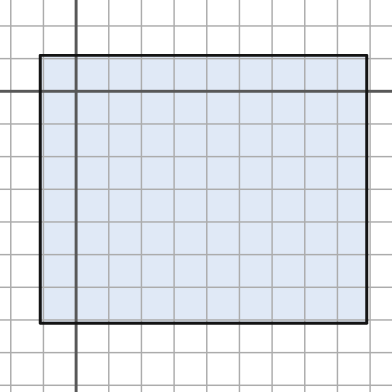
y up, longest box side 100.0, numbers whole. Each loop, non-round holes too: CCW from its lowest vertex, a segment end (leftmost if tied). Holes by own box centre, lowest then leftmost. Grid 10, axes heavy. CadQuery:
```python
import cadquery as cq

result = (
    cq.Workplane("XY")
    .moveTo(-11.0, -71.0)
    .lineTo(89.0, -71.0)
    .lineTo(89.0, 11.0)
    .lineTo(-11.0, 11.0)
    .close()
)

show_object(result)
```